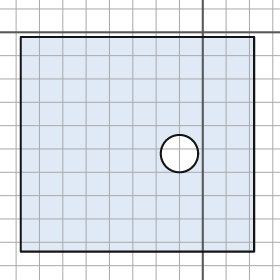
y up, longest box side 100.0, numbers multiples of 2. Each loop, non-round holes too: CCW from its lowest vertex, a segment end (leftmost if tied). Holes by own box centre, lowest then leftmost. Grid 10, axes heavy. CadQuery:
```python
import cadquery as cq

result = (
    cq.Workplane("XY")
    .moveTo(-78.0, -94.0)
    .lineTo(22.0, -94.0)
    .lineTo(22.0, -2.0)
    .lineTo(-78.0, -2.0)
    .close()
    .moveTo(-10.0, -52.0)
    .circle(8.0)
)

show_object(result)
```